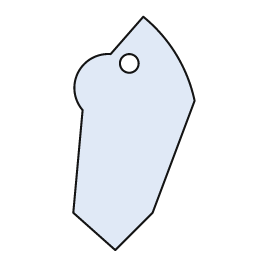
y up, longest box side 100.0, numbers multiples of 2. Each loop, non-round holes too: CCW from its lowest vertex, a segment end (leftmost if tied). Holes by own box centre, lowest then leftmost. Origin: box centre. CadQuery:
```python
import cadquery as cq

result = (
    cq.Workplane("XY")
    .moveTo(-8.0, -50.0)
    .lineTo(8.0, -34.0)
    .lineTo(26.0, 14.0)
    .threePointArc((18.0, 34.0), (4.0, 50.0))
    .lineTo(-10.0, 34.0)
    .threePointArc((-24.0, 26.0), (-22.0, 10.0))
    .lineTo(-26.0, -34.0)
    .close()
    .moveTo(-2.0, 30.0)
    .circle(4.0)
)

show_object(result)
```